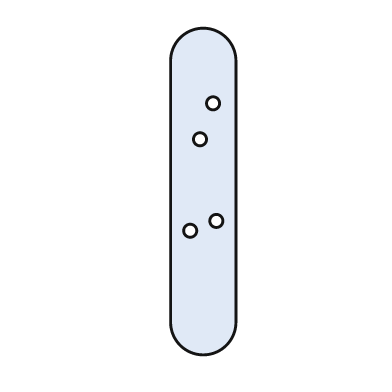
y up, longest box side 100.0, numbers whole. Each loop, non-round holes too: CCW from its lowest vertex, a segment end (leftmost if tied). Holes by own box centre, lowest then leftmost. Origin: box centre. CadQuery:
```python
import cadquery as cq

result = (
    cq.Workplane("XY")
    .moveTo(-10.0, -40.0)
    .threePointArc((0.0, -50.0), (10.0, -40.0))
    .lineTo(10.0, 40.0)
    .threePointArc((0.0, 50.0), (-10.0, 40.0))
    .close()
    .moveTo(-4.0, -12.0)
    .circle(2.0)
    .moveTo(4.0, -9.0)
    .circle(2.0)
    .moveTo(-1.0, 16.0)
    .circle(2.0)
    .moveTo(3.0, 27.0)
    .circle(2.0)
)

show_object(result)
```